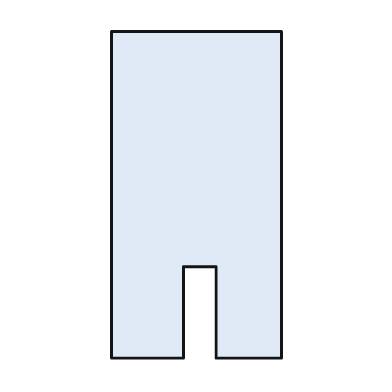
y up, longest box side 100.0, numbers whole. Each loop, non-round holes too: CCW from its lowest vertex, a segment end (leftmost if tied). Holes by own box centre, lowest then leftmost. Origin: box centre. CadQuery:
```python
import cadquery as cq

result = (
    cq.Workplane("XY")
    .moveTo(-26.0, -50.0)
    .lineTo(-4.0, -50.0)
    .lineTo(-4.0, -22.0)
    .lineTo(6.0, -22.0)
    .lineTo(6.0, -50.0)
    .lineTo(26.0, -50.0)
    .lineTo(26.0, 50.0)
    .lineTo(-26.0, 50.0)
    .close()
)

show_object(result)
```